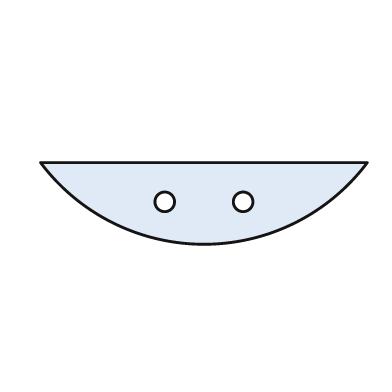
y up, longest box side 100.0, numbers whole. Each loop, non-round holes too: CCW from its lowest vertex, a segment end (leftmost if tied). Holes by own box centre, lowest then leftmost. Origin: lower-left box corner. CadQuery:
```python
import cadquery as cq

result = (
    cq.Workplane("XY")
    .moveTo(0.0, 25.0)
    .threePointArc((50.0, 0.0), (100.0, 25.0))
    .close()
    .moveTo(38.0, 13.0)
    .circle(3.0)
    .moveTo(62.0, 13.0)
    .circle(3.0)
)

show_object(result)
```